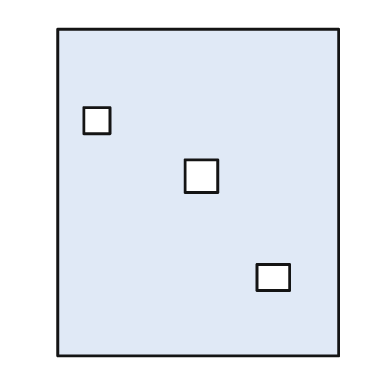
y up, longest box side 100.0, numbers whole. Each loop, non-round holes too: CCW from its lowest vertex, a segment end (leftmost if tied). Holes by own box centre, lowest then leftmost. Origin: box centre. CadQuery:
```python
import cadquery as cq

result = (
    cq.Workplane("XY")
    .moveTo(-43.0, -50.0)
    .lineTo(43.0, -50.0)
    .lineTo(43.0, 50.0)
    .lineTo(-43.0, 50.0)
    .close()
    .moveTo(18.0, -30.0)
    .lineTo(28.0, -30.0)
    .lineTo(28.0, -22.0)
    .lineTo(18.0, -22.0)
    .close()
    .moveTo(-4.0, 0.0)
    .lineTo(6.0, 0.0)
    .lineTo(6.0, 10.0)
    .lineTo(-4.0, 10.0)
    .close()
    .moveTo(-35.0, 18.0)
    .lineTo(-27.0, 18.0)
    .lineTo(-27.0, 26.0)
    .lineTo(-35.0, 26.0)
    .close()
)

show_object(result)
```